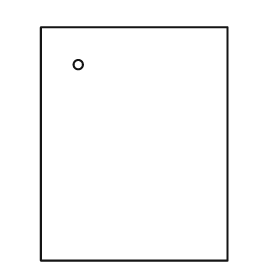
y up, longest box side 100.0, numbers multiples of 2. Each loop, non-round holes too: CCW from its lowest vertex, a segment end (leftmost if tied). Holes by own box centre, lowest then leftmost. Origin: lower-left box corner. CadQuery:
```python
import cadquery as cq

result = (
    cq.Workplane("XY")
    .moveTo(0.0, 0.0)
    .lineTo(80.0, 0.0)
    .lineTo(80.0, 100.0)
    .lineTo(0.0, 100.0)
    .close()
    .moveTo(16.0, 84.0)
    .circle(2.0)
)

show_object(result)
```